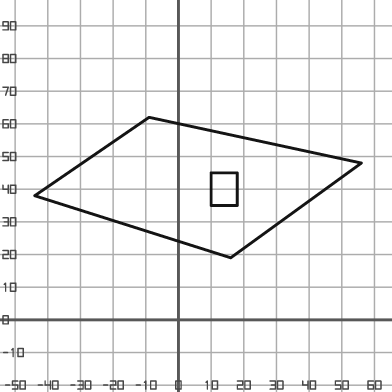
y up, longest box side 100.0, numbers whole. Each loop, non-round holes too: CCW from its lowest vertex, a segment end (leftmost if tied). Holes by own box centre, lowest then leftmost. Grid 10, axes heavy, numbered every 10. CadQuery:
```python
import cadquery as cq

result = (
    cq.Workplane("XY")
    .moveTo(16.0, 19.0)
    .lineTo(56.0, 48.0)
    .lineTo(-9.0, 62.0)
    .lineTo(-44.0, 38.0)
    .close()
    .moveTo(10.0, 35.0)
    .lineTo(18.0, 35.0)
    .lineTo(18.0, 45.0)
    .lineTo(10.0, 45.0)
    .close()
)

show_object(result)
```